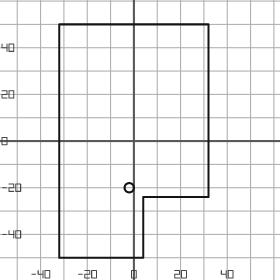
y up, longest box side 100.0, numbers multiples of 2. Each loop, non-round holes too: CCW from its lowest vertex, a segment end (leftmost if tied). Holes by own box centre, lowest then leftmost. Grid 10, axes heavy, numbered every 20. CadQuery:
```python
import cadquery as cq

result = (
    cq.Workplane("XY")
    .moveTo(-32.0, -50.0)
    .lineTo(4.0, -50.0)
    .lineTo(4.0, -24.0)
    .lineTo(32.0, -24.0)
    .lineTo(32.0, 50.0)
    .lineTo(-32.0, 50.0)
    .close()
    .moveTo(-2.0, -20.0)
    .circle(2.0)
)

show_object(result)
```